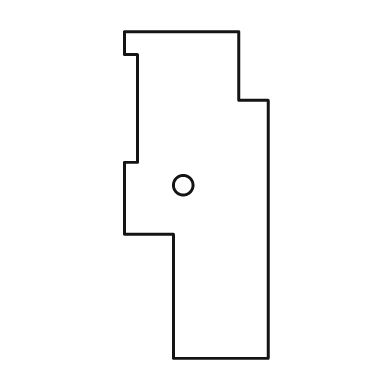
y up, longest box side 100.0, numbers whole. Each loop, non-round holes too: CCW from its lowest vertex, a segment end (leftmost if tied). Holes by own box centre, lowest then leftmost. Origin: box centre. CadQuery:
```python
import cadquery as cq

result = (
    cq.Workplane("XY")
    .moveTo(-7.0, -50.0)
    .lineTo(22.0, -50.0)
    .lineTo(22.0, 29.0)
    .lineTo(13.0, 29.0)
    .lineTo(13.0, 50.0)
    .lineTo(-22.0, 50.0)
    .lineTo(-22.0, 43.0)
    .lineTo(-18.0, 43.0)
    .lineTo(-18.0, 10.0)
    .lineTo(-22.0, 10.0)
    .lineTo(-22.0, -12.0)
    .lineTo(-7.0, -12.0)
    .close()
    .moveTo(-4.0, 3.0)
    .circle(3.0)
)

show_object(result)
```